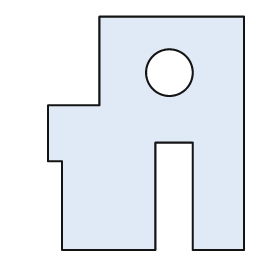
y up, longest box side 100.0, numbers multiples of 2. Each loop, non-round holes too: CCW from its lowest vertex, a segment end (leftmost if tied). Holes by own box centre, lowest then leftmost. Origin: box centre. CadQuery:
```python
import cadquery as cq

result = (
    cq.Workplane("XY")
    .moveTo(-36.0, -50.0)
    .lineTo(4.0, -50.0)
    .lineTo(4.0, -4.0)
    .lineTo(20.0, -4.0)
    .lineTo(20.0, -50.0)
    .lineTo(42.0, -50.0)
    .lineTo(42.0, 50.0)
    .lineTo(-20.0, 50.0)
    .lineTo(-20.0, 12.0)
    .lineTo(-42.0, 12.0)
    .lineTo(-42.0, -12.0)
    .lineTo(-36.0, -12.0)
    .close()
    .moveTo(10.0, 26.0)
    .circle(10.0)
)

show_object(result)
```